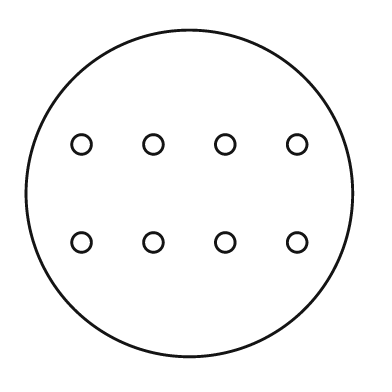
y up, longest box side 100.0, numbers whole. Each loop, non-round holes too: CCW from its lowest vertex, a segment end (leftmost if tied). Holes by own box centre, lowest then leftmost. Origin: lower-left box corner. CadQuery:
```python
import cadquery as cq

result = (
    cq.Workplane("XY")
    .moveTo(50.0, 50.0)
    .circle(50.0)
    .moveTo(17.0, 35.0)
    .circle(3.0)
    .moveTo(39.0, 35.0)
    .circle(3.0)
    .moveTo(61.0, 35.0)
    .circle(3.0)
    .moveTo(83.0, 35.0)
    .circle(3.0)
    .moveTo(17.0, 65.0)
    .circle(3.0)
    .moveTo(39.0, 65.0)
    .circle(3.0)
    .moveTo(61.0, 65.0)
    .circle(3.0)
    .moveTo(83.0, 65.0)
    .circle(3.0)
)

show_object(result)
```